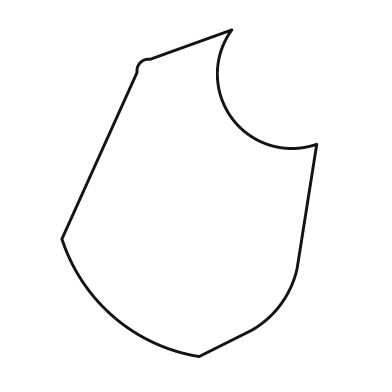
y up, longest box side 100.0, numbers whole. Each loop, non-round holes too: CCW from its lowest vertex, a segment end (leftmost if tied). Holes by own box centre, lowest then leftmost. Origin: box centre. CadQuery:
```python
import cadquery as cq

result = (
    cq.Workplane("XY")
    .moveTo(3.0, -50.0)
    .lineTo(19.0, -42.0)
    .threePointArc((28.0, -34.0), (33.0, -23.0))
    .lineTo(39.0, 15.0)
    .threePointArc((13.0, 23.0), (13.0, 50.0))
    .lineTo(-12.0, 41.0)
    .threePointArc((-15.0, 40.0), (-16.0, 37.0))
    .lineTo(-39.0, -14.0)
    .threePointArc((-23.0, -38.0), (3.0, -50.0))
    .close()
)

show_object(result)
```